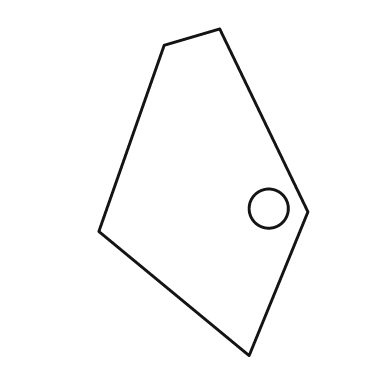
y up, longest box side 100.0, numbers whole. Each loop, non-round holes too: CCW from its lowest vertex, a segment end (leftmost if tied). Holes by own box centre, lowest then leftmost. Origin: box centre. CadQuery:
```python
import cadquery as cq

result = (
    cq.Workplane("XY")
    .moveTo(14.0, -50.0)
    .lineTo(32.0, -6.0)
    .lineTo(5.0, 50.0)
    .lineTo(-12.0, 45.0)
    .lineTo(-32.0, -12.0)
    .close()
    .moveTo(20.0, -5.0)
    .circle(6.0)
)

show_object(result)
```